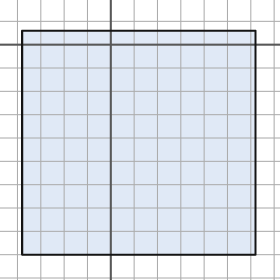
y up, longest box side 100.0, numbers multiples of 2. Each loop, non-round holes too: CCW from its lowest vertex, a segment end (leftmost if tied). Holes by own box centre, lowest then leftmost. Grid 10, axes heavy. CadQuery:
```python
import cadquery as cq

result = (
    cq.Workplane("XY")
    .moveTo(-38.0, -90.0)
    .lineTo(62.0, -90.0)
    .lineTo(62.0, 6.0)
    .lineTo(-38.0, 6.0)
    .close()
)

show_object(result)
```